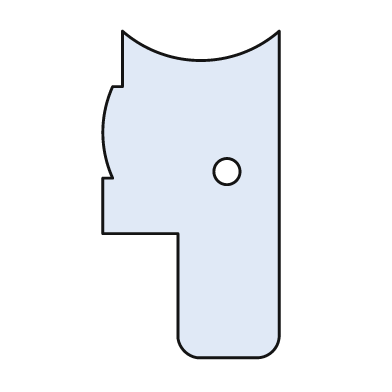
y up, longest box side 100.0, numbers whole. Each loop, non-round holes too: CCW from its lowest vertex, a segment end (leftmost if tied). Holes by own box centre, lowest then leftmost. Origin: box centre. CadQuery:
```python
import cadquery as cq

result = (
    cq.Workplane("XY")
    .moveTo(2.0, -50.0)
    .lineTo(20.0, -50.0)
    .threePointArc((25.0, -48.0), (27.0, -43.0))
    .lineTo(27.0, 50.0)
    .threePointArc((3.0, 41.0), (-21.0, 50.0))
    .lineTo(-21.0, 33.0)
    .lineTo(-24.0, 33.0)
    .threePointArc((-27.0, 19.0), (-24.0, 5.0))
    .lineTo(-27.0, 5.0)
    .lineTo(-27.0, -12.0)
    .lineTo(-4.0, -12.0)
    .lineTo(-4.0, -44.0)
    .threePointArc((-2.0, -48.0), (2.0, -50.0))
    .close()
    .moveTo(11.0, 7.0)
    .circle(4.0)
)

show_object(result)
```